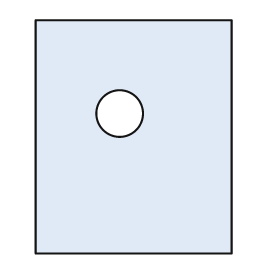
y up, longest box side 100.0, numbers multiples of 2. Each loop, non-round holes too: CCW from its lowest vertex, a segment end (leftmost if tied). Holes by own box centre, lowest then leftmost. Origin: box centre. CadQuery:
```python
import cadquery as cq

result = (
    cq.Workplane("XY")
    .moveTo(-42.0, -50.0)
    .lineTo(42.0, -50.0)
    .lineTo(42.0, 50.0)
    .lineTo(-42.0, 50.0)
    .close()
    .moveTo(-6.0, 10.0)
    .circle(10.0)
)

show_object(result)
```